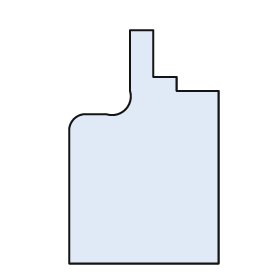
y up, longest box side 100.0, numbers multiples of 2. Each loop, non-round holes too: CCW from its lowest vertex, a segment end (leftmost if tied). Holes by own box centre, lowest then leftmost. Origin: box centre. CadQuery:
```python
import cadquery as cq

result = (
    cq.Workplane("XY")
    .moveTo(-32.0, -50.0)
    .lineTo(32.0, -50.0)
    .lineTo(32.0, 24.0)
    .lineTo(14.0, 24.0)
    .lineTo(14.0, 30.0)
    .lineTo(4.0, 30.0)
    .lineTo(4.0, 50.0)
    .lineTo(-6.0, 50.0)
    .lineTo(-6.0, 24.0)
    .threePointArc((-8.0, 16.0), (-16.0, 14.0))
    .lineTo(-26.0, 14.0)
    .threePointArc((-30.0, 12.0), (-32.0, 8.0))
    .close()
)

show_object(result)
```